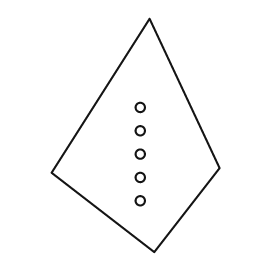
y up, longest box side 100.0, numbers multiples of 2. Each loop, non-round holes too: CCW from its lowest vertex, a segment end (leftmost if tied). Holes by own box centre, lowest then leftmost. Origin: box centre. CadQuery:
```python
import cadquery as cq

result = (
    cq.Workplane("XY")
    .moveTo(8.0, -50.0)
    .lineTo(36.0, -14.0)
    .lineTo(6.0, 50.0)
    .lineTo(-36.0, -16.0)
    .close()
    .moveTo(2.0, -28.0)
    .circle(2.0)
    .moveTo(2.0, -18.0)
    .circle(2.0)
    .moveTo(2.0, -8.0)
    .circle(2.0)
    .moveTo(2.0, 2.0)
    .circle(2.0)
    .moveTo(2.0, 12.0)
    .circle(2.0)
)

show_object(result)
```